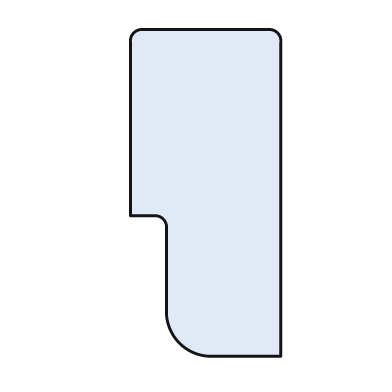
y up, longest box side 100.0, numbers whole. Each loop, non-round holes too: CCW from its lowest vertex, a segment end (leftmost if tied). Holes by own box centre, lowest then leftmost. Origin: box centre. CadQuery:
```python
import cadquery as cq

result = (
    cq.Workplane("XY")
    .moveTo(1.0, -50.0)
    .lineTo(23.0, -50.0)
    .lineTo(23.0, 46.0)
    .threePointArc((22.0, 49.0), (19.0, 50.0))
    .lineTo(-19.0, 50.0)
    .threePointArc((-22.0, 49.0), (-23.0, 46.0))
    .lineTo(-23.0, -7.0)
    .lineTo(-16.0, -7.0)
    .threePointArc((-13.0, -8.0), (-12.0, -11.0))
    .lineTo(-12.0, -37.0)
    .threePointArc((-8.0, -46.0), (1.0, -50.0))
    .close()
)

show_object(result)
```